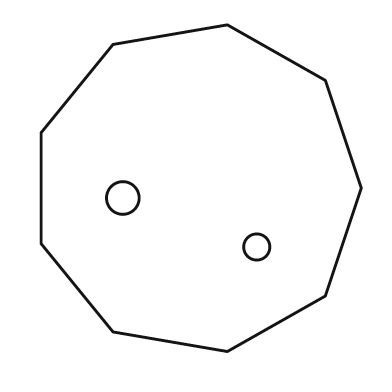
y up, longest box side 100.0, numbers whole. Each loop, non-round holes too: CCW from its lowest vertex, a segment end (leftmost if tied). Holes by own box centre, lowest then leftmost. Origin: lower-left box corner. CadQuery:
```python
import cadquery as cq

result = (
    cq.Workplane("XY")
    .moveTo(57.0, 0.0)
    .lineTo(87.0, 17.0)
    .lineTo(98.0, 50.0)
    .lineTo(87.0, 83.0)
    .lineTo(57.0, 100.0)
    .lineTo(22.0, 94.0)
    .lineTo(0.0, 67.0)
    .lineTo(0.0, 33.0)
    .lineTo(22.0, 6.0)
    .close()
    .moveTo(66.0, 32.0)
    .circle(4.0)
    .moveTo(25.0, 47.0)
    .circle(5.0)
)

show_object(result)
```